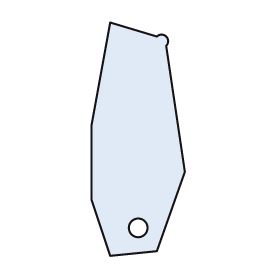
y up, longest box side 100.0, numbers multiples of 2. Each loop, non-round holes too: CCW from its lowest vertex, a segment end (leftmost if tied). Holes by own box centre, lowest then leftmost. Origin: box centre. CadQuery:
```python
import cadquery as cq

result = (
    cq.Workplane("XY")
    .moveTo(-12.0, -50.0)
    .lineTo(8.0, -48.0)
    .lineTo(20.0, -14.0)
    .lineTo(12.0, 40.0)
    .threePointArc((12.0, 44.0), (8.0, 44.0))
    .lineTo(-12.0, 50.0)
    .lineTo(-20.0, 6.0)
    .lineTo(-20.0, -26.0)
    .close()
    .moveTo(0.0, -38.0)
    .circle(4.0)
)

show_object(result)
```